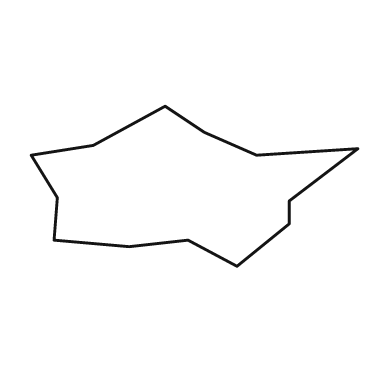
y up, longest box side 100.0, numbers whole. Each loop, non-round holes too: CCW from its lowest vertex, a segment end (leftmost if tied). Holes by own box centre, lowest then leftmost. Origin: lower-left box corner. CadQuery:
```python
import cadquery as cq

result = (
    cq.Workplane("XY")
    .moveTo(63.0, 0.0)
    .lineTo(79.0, 13.0)
    .lineTo(79.0, 20.0)
    .lineTo(100.0, 36.0)
    .lineTo(69.0, 34.0)
    .lineTo(53.0, 41.0)
    .lineTo(41.0, 49.0)
    .lineTo(19.0, 37.0)
    .lineTo(0.0, 34.0)
    .lineTo(8.0, 21.0)
    .lineTo(7.0, 8.0)
    .lineTo(30.0, 6.0)
    .lineTo(48.0, 8.0)
    .close()
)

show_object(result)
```